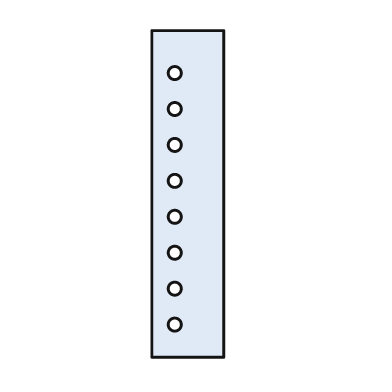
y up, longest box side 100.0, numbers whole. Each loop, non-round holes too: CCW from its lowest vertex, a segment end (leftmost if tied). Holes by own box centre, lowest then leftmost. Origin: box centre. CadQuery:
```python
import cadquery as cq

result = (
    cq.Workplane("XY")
    .moveTo(-11.0, -50.0)
    .lineTo(11.0, -50.0)
    .lineTo(11.0, 50.0)
    .lineTo(-11.0, 50.0)
    .close()
    .moveTo(-4.0, -40.0)
    .circle(2.0)
    .moveTo(-4.0, -29.0)
    .circle(2.0)
    .moveTo(-4.0, -18.0)
    .circle(2.0)
    .moveTo(-4.0, -7.0)
    .circle(2.0)
    .moveTo(-4.0, 4.0)
    .circle(2.0)
    .moveTo(-4.0, 15.0)
    .circle(2.0)
    .moveTo(-4.0, 26.0)
    .circle(2.0)
    .moveTo(-4.0, 37.0)
    .circle(2.0)
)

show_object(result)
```